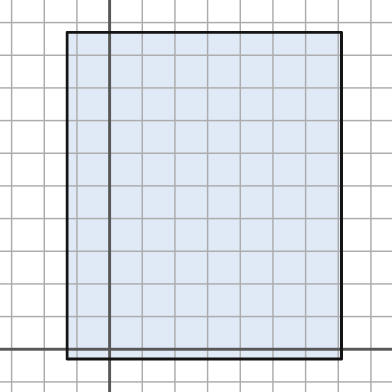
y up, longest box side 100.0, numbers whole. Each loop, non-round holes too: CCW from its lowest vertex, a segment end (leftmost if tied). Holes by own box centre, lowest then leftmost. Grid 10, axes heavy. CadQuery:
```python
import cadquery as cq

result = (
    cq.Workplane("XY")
    .moveTo(-13.0, -3.0)
    .lineTo(71.0, -3.0)
    .lineTo(71.0, 97.0)
    .lineTo(-13.0, 97.0)
    .close()
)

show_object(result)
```